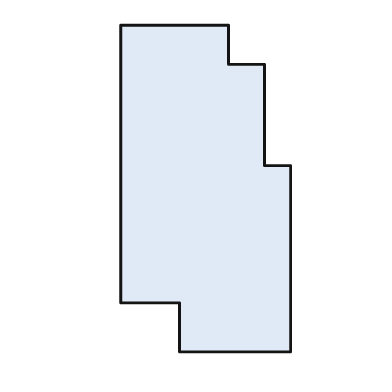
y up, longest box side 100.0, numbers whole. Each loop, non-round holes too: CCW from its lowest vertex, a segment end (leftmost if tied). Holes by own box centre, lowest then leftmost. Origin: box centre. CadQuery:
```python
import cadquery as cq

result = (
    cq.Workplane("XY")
    .moveTo(-8.0, -50.0)
    .lineTo(26.0, -50.0)
    .lineTo(26.0, 7.0)
    .lineTo(18.0, 7.0)
    .lineTo(18.0, 38.0)
    .lineTo(7.0, 38.0)
    .lineTo(7.0, 50.0)
    .lineTo(-26.0, 50.0)
    .lineTo(-26.0, -35.0)
    .lineTo(-8.0, -35.0)
    .close()
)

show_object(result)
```